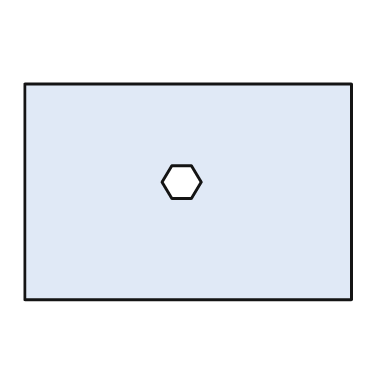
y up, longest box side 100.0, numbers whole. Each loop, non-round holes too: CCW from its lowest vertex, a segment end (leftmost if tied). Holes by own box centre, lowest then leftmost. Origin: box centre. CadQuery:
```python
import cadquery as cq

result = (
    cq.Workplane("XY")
    .moveTo(-50.0, -33.0)
    .lineTo(50.0, -33.0)
    .lineTo(50.0, 33.0)
    .lineTo(-50.0, 33.0)
    .close()
    .moveTo(-5.0, -2.0)
    .lineTo(1.0, -2.0)
    .lineTo(4.0, 3.0)
    .lineTo(1.0, 8.0)
    .lineTo(-5.0, 8.0)
    .lineTo(-8.0, 3.0)
    .close()
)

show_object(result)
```